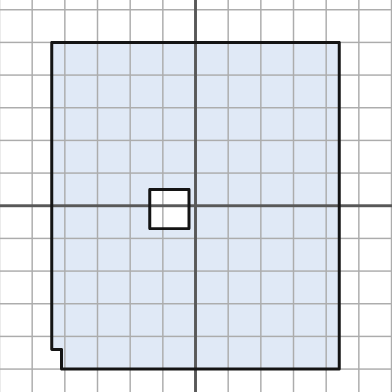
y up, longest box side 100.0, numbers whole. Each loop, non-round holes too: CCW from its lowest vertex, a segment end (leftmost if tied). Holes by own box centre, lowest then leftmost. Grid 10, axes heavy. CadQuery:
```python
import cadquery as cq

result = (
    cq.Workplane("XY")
    .moveTo(-41.0, -50.0)
    .lineTo(44.0, -50.0)
    .lineTo(44.0, 50.0)
    .lineTo(-44.0, 50.0)
    .lineTo(-44.0, -44.0)
    .lineTo(-41.0, -44.0)
    .close()
    .moveTo(-14.0, -7.0)
    .lineTo(-2.0, -7.0)
    .lineTo(-2.0, 5.0)
    .lineTo(-14.0, 5.0)
    .close()
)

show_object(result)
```